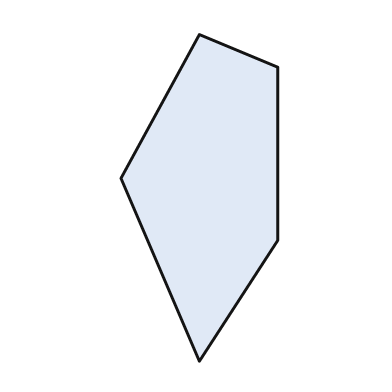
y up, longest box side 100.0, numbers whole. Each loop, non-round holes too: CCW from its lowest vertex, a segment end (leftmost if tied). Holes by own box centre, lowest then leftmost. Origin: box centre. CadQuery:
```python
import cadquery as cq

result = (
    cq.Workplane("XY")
    .moveTo(0.0, -50.0)
    .lineTo(24.0, -13.0)
    .lineTo(24.0, 40.0)
    .lineTo(0.0, 50.0)
    .lineTo(-24.0, 6.0)
    .close()
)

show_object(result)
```